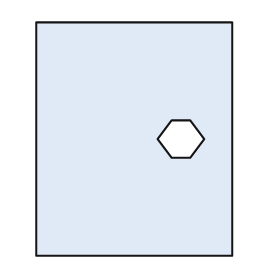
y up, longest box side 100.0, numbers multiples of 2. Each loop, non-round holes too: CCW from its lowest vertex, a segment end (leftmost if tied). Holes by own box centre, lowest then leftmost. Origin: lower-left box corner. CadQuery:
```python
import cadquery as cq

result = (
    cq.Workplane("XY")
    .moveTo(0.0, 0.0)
    .lineTo(84.0, 0.0)
    .lineTo(84.0, 100.0)
    .lineTo(0.0, 100.0)
    .close()
    .moveTo(58.0, 42.0)
    .lineTo(66.0, 42.0)
    .lineTo(72.0, 50.0)
    .lineTo(66.0, 58.0)
    .lineTo(58.0, 58.0)
    .lineTo(52.0, 50.0)
    .close()
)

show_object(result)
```